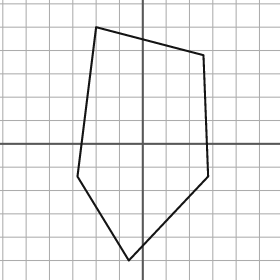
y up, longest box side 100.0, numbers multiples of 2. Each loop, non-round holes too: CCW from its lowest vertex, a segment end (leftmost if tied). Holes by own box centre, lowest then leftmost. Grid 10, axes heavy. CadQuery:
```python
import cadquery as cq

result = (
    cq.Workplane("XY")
    .moveTo(-6.0, -50.0)
    .lineTo(28.0, -14.0)
    .lineTo(26.0, 38.0)
    .lineTo(-20.0, 50.0)
    .lineTo(-28.0, -14.0)
    .close()
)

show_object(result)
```